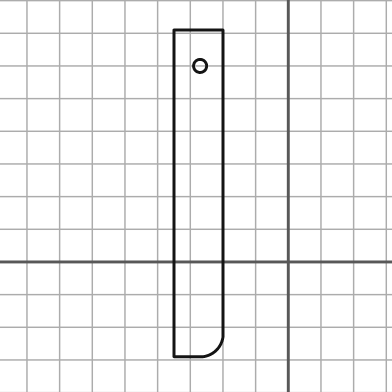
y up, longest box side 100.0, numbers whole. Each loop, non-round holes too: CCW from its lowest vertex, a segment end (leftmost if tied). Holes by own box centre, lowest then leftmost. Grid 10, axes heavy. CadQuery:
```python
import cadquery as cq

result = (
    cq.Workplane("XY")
    .moveTo(-35.0, -29.0)
    .lineTo(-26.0, -29.0)
    .threePointArc((-22.0, -27.0), (-20.0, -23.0))
    .lineTo(-20.0, 71.0)
    .lineTo(-35.0, 71.0)
    .close()
    .moveTo(-27.0, 60.0)
    .circle(2.0)
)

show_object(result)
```